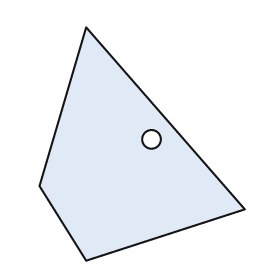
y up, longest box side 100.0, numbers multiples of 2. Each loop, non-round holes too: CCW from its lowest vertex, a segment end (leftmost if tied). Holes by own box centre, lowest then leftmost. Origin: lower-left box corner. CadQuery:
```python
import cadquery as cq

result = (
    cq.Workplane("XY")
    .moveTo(20.0, 0.0)
    .lineTo(88.0, 22.0)
    .lineTo(20.0, 100.0)
    .lineTo(0.0, 32.0)
    .close()
    .moveTo(48.0, 52.0)
    .circle(4.0)
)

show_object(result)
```